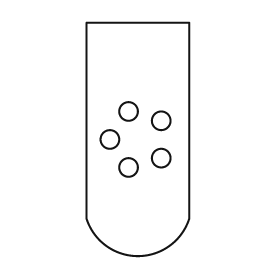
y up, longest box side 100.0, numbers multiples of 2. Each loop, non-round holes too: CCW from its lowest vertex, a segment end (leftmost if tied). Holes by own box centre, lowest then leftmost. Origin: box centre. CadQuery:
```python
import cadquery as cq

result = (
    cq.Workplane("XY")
    .moveTo(-22.0, -34.0)
    .threePointArc((0.0, -50.0), (22.0, -34.0))
    .lineTo(22.0, 50.0)
    .lineTo(-22.0, 50.0)
    .close()
    .moveTo(-4.0, -12.0)
    .circle(4.0)
    .moveTo(10.0, -8.0)
    .circle(4.0)
    .moveTo(-12.0, 0.0)
    .circle(4.0)
    .moveTo(10.0, 8.0)
    .circle(4.0)
    .moveTo(-4.0, 12.0)
    .circle(4.0)
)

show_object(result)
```